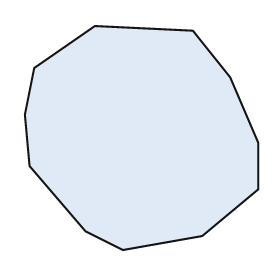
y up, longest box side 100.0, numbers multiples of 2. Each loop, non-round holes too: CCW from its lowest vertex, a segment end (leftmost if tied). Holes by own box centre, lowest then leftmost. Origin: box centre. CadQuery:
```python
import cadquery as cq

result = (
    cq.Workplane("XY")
    .moveTo(-8.0, -48.0)
    .lineTo(26.0, -42.0)
    .lineTo(50.0, -22.0)
    .lineTo(50.0, -2.0)
    .lineTo(38.0, 26.0)
    .lineTo(22.0, 46.0)
    .lineTo(-20.0, 48.0)
    .lineTo(-46.0, 30.0)
    .lineTo(-50.0, 10.0)
    .lineTo(-48.0, -12.0)
    .lineTo(-24.0, -40.0)
    .close()
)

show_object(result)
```